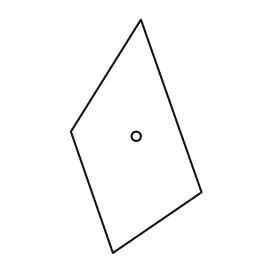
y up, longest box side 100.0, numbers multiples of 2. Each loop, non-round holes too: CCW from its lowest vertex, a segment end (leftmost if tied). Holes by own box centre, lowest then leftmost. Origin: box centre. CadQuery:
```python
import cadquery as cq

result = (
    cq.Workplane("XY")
    .moveTo(-10.0, -50.0)
    .lineTo(28.0, -24.0)
    .lineTo(2.0, 50.0)
    .lineTo(-28.0, 2.0)
    .close()
    .moveTo(0.0, 0.0)
    .circle(2.0)
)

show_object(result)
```